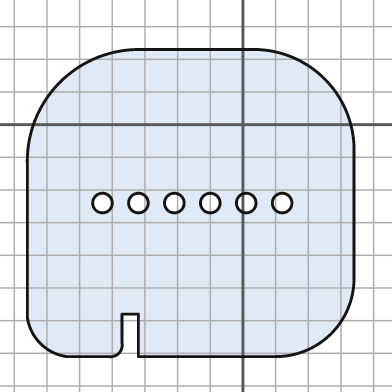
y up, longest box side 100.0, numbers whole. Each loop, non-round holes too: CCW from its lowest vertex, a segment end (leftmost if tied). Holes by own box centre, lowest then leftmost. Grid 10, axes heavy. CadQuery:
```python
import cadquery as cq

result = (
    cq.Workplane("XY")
    .moveTo(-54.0, -71.0)
    .lineTo(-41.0, -71.0)
    .threePointArc((-38.0, -70.0), (-37.0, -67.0))
    .lineTo(-37.0, -58.0)
    .lineTo(-32.0, -58.0)
    .lineTo(-32.0, -71.0)
    .lineTo(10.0, -71.0)
    .threePointArc((27.0, -64.0), (34.0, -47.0))
    .lineTo(34.0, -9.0)
    .threePointArc((25.0, 14.0), (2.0, 23.0))
    .lineTo(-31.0, 23.0)
    .threePointArc((-56.0, 13.0), (-66.0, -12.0))
    .lineTo(-66.0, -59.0)
    .threePointArc((-62.0, -67.0), (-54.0, -71.0))
    .close()
    .moveTo(-43.0, -24.0)
    .circle(3.0)
    .moveTo(-32.0, -24.0)
    .circle(3.0)
    .moveTo(-21.0, -24.0)
    .circle(3.0)
    .moveTo(-10.0, -24.0)
    .circle(3.0)
    .moveTo(1.0, -24.0)
    .circle(3.0)
    .moveTo(12.0, -24.0)
    .circle(3.0)
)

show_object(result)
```